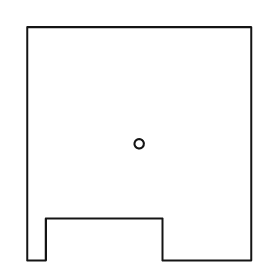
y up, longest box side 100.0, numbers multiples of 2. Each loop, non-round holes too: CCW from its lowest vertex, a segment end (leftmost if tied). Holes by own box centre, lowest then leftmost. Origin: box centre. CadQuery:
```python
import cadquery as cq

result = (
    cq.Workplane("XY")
    .moveTo(-48.0, -50.0)
    .lineTo(-40.0, -50.0)
    .lineTo(-40.0, -32.0)
    .lineTo(10.0, -32.0)
    .lineTo(10.0, -50.0)
    .lineTo(48.0, -50.0)
    .lineTo(48.0, 50.0)
    .lineTo(-48.0, 50.0)
    .close()
    .moveTo(0.0, 0.0)
    .circle(2.0)
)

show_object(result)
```